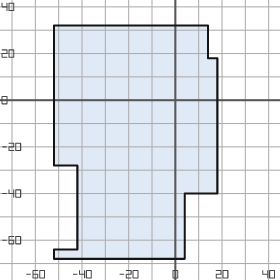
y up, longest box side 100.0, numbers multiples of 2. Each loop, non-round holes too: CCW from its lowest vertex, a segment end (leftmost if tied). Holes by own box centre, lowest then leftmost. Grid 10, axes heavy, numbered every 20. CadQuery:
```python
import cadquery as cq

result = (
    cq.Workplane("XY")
    .moveTo(-52.0, -68.0)
    .lineTo(4.0, -68.0)
    .lineTo(4.0, -40.0)
    .lineTo(18.0, -40.0)
    .lineTo(18.0, 18.0)
    .lineTo(14.0, 18.0)
    .lineTo(14.0, 32.0)
    .lineTo(-52.0, 32.0)
    .lineTo(-52.0, -28.0)
    .lineTo(-42.0, -28.0)
    .lineTo(-42.0, -64.0)
    .lineTo(-52.0, -64.0)
    .close()
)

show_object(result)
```